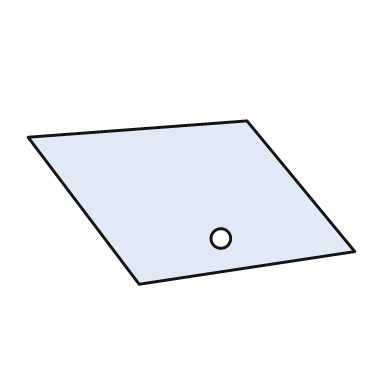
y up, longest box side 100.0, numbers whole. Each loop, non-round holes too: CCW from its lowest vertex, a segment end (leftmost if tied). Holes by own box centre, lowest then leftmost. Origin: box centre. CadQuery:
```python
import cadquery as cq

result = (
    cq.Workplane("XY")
    .moveTo(-16.0, -25.0)
    .lineTo(50.0, -15.0)
    .lineTo(17.0, 25.0)
    .lineTo(-50.0, 20.0)
    .close()
    .moveTo(9.0, -11.0)
    .circle(3.0)
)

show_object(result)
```